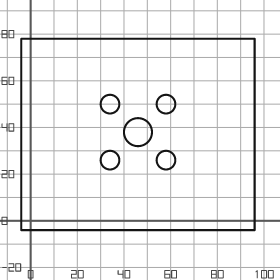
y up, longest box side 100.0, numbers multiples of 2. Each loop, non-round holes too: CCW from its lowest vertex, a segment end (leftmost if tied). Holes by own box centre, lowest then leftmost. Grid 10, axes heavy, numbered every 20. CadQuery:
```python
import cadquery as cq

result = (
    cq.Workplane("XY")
    .moveTo(-4.0, -4.0)
    .lineTo(96.0, -4.0)
    .lineTo(96.0, 78.0)
    .lineTo(-4.0, 78.0)
    .close()
    .moveTo(34.0, 26.0)
    .circle(4.0)
    .moveTo(58.0, 26.0)
    .circle(4.0)
    .moveTo(46.0, 38.0)
    .circle(6.0)
    .moveTo(34.0, 50.0)
    .circle(4.0)
    .moveTo(58.0, 50.0)
    .circle(4.0)
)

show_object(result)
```